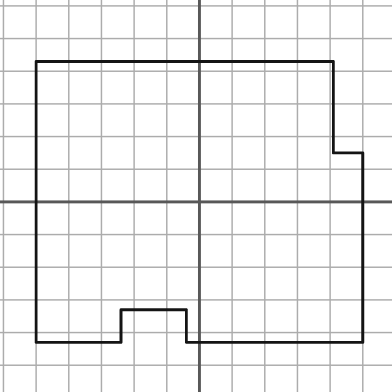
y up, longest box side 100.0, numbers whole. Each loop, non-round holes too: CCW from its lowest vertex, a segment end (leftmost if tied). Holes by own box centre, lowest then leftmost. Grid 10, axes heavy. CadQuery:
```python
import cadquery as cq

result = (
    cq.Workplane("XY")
    .moveTo(-50.0, -43.0)
    .lineTo(-24.0, -43.0)
    .lineTo(-24.0, -33.0)
    .lineTo(-4.0, -33.0)
    .lineTo(-4.0, -43.0)
    .lineTo(50.0, -43.0)
    .lineTo(50.0, 15.0)
    .lineTo(41.0, 15.0)
    .lineTo(41.0, 43.0)
    .lineTo(-50.0, 43.0)
    .close()
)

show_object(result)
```